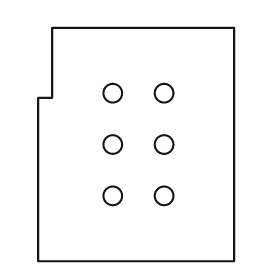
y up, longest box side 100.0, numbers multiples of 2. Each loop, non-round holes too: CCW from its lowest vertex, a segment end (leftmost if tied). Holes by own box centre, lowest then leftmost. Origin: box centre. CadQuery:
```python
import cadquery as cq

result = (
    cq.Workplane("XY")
    .moveTo(-42.0, -50.0)
    .lineTo(42.0, -50.0)
    .lineTo(42.0, 50.0)
    .lineTo(-36.0, 50.0)
    .lineTo(-36.0, 20.0)
    .lineTo(-42.0, 20.0)
    .close()
    .moveTo(-10.0, -22.0)
    .circle(4.0)
    .moveTo(12.0, -22.0)
    .circle(4.0)
    .moveTo(-10.0, 0.0)
    .circle(4.0)
    .moveTo(12.0, 0.0)
    .circle(4.0)
    .moveTo(-10.0, 22.0)
    .circle(4.0)
    .moveTo(12.0, 22.0)
    .circle(4.0)
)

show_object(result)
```